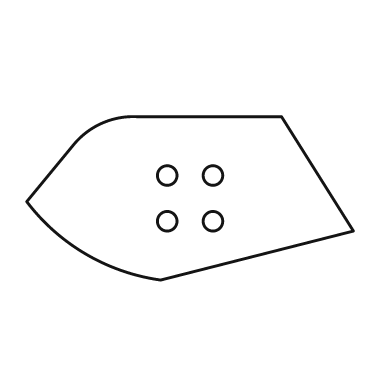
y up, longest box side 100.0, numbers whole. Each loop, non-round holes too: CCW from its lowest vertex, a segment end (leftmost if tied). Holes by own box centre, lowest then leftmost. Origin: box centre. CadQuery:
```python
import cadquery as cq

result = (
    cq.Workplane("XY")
    .moveTo(-9.0, -25.0)
    .lineTo(50.0, -10.0)
    .lineTo(28.0, 25.0)
    .lineTo(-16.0, 25.0)
    .threePointArc((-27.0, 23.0), (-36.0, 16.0))
    .lineTo(-50.0, -1.0)
    .threePointArc((-32.0, -17.0), (-9.0, -25.0))
    .close()
    .moveTo(-7.0, -7.0)
    .circle(3.0)
    .moveTo(7.0, -7.0)
    .circle(3.0)
    .moveTo(-7.0, 7.0)
    .circle(3.0)
    .moveTo(7.0, 7.0)
    .circle(3.0)
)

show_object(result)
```